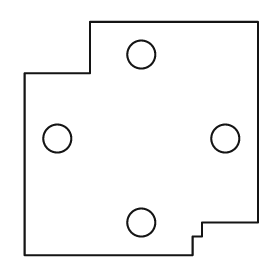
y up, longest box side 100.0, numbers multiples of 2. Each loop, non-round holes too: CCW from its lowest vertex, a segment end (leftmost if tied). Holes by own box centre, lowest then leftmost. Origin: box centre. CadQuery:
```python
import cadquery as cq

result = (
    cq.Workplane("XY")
    .moveTo(-50.0, -50.0)
    .lineTo(22.0, -50.0)
    .lineTo(22.0, -42.0)
    .lineTo(26.0, -42.0)
    .lineTo(26.0, -36.0)
    .lineTo(50.0, -36.0)
    .lineTo(50.0, 50.0)
    .lineTo(-22.0, 50.0)
    .lineTo(-22.0, 28.0)
    .lineTo(-50.0, 28.0)
    .close()
    .moveTo(0.0, -36.0)
    .circle(6.0)
    .moveTo(-36.0, 0.0)
    .circle(6.0)
    .moveTo(36.0, 0.0)
    .circle(6.0)
    .moveTo(0.0, 36.0)
    .circle(6.0)
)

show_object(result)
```